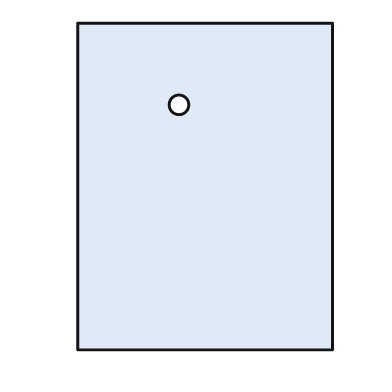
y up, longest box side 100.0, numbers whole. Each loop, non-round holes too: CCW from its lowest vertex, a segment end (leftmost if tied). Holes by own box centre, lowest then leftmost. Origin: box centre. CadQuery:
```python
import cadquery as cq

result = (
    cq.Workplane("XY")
    .moveTo(-39.0, -50.0)
    .lineTo(39.0, -50.0)
    .lineTo(39.0, 50.0)
    .lineTo(-39.0, 50.0)
    .close()
    .moveTo(-8.0, 25.0)
    .circle(3.0)
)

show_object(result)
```